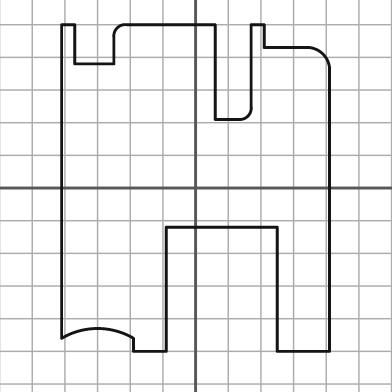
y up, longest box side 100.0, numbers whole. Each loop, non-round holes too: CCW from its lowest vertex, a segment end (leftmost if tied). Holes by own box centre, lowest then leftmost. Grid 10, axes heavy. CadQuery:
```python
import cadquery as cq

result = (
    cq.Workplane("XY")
    .moveTo(-19.0, -50.0)
    .lineTo(-9.0, -50.0)
    .lineTo(-9.0, -12.0)
    .lineTo(25.0, -12.0)
    .lineTo(25.0, -50.0)
    .lineTo(41.0, -50.0)
    .lineTo(41.0, 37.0)
    .threePointArc((39.0, 41.0), (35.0, 43.0))
    .lineTo(21.0, 43.0)
    .lineTo(21.0, 50.0)
    .lineTo(17.0, 50.0)
    .lineTo(17.0, 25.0)
    .threePointArc((16.0, 22.0), (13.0, 21.0))
    .lineTo(6.0, 21.0)
    .lineTo(6.0, 50.0)
    .lineTo(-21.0, 50.0)
    .threePointArc((-24.0, 49.0), (-25.0, 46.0))
    .lineTo(-25.0, 38.0)
    .lineTo(-37.0, 38.0)
    .lineTo(-37.0, 50.0)
    .lineTo(-41.0, 50.0)
    .lineTo(-41.0, -46.0)
    .threePointArc((-30.0, -43.0), (-19.0, -46.0))
    .close()
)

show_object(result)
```